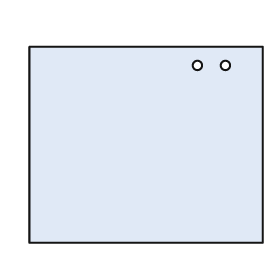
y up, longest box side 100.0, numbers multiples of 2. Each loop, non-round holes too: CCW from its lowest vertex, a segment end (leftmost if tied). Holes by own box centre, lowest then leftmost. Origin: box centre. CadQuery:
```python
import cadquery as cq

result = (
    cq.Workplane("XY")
    .moveTo(-50.0, -42.0)
    .lineTo(50.0, -42.0)
    .lineTo(50.0, 42.0)
    .lineTo(-50.0, 42.0)
    .close()
    .moveTo(22.0, 34.0)
    .circle(2.0)
    .moveTo(34.0, 34.0)
    .circle(2.0)
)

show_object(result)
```